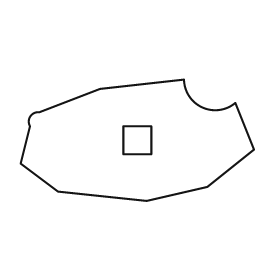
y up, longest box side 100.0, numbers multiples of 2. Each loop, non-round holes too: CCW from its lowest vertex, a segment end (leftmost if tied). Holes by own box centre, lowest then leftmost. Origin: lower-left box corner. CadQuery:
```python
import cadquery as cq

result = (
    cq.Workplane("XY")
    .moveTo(54.0, 0.0)
    .lineTo(80.0, 6.0)
    .lineTo(100.0, 22.0)
    .lineTo(92.0, 42.0)
    .threePointArc((78.0, 40.0), (70.0, 52.0))
    .lineTo(34.0, 48.0)
    .lineTo(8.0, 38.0)
    .threePointArc((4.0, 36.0), (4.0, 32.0))
    .lineTo(0.0, 16.0)
    .lineTo(16.0, 4.0)
    .close()
    .moveTo(44.0, 20.0)
    .lineTo(56.0, 20.0)
    .lineTo(56.0, 32.0)
    .lineTo(44.0, 32.0)
    .close()
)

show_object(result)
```